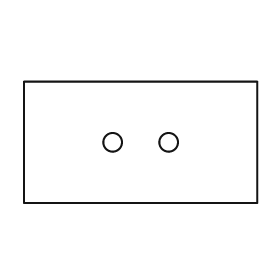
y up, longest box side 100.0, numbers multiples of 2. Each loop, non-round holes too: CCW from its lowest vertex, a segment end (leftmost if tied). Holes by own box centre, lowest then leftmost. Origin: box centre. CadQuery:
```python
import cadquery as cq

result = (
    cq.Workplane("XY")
    .moveTo(-50.0, -26.0)
    .lineTo(50.0, -26.0)
    .lineTo(50.0, 26.0)
    .lineTo(-50.0, 26.0)
    .close()
    .moveTo(-12.0, 0.0)
    .circle(4.0)
    .moveTo(12.0, 0.0)
    .circle(4.0)
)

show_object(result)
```